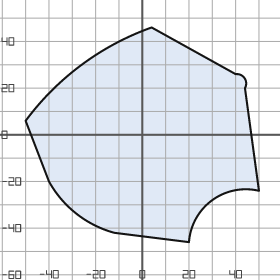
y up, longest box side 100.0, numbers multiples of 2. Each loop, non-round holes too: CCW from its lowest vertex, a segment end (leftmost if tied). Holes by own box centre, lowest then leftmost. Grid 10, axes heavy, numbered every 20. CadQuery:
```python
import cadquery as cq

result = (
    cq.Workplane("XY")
    .moveTo(20.0, -46.0)
    .threePointArc((30.0, -28.0), (50.0, -24.0))
    .lineTo(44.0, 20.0)
    .threePointArc((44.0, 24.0), (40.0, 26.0))
    .lineTo(4.0, 46.0)
    .threePointArc((-26.0, 30.0), (-50.0, 6.0))
    .lineTo(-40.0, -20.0)
    .threePointArc((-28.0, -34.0), (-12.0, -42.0))
    .close()
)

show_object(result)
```